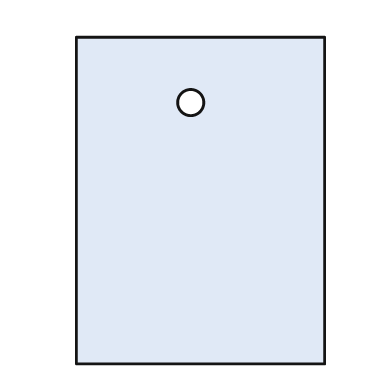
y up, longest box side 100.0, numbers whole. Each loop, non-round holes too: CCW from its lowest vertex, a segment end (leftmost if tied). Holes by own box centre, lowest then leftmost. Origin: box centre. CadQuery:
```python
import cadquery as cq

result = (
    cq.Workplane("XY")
    .moveTo(-38.0, -50.0)
    .lineTo(38.0, -50.0)
    .lineTo(38.0, 50.0)
    .lineTo(-38.0, 50.0)
    .close()
    .moveTo(-3.0, 30.0)
    .circle(4.0)
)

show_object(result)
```